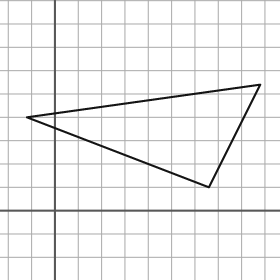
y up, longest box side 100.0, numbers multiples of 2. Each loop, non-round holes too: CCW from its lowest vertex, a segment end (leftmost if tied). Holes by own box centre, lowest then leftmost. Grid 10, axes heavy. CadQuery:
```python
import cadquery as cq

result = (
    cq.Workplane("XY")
    .moveTo(66.0, 10.0)
    .lineTo(88.0, 54.0)
    .lineTo(-12.0, 40.0)
    .close()
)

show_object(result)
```